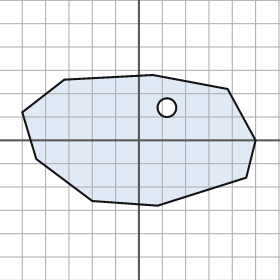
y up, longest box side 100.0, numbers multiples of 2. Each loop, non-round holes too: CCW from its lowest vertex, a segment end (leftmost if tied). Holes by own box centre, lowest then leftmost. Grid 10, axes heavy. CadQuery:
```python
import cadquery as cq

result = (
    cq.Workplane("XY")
    .moveTo(8.0, -28.0)
    .lineTo(46.0, -16.0)
    .lineTo(50.0, 0.0)
    .lineTo(38.0, 22.0)
    .lineTo(6.0, 28.0)
    .lineTo(-32.0, 26.0)
    .lineTo(-50.0, 12.0)
    .lineTo(-44.0, -8.0)
    .lineTo(-20.0, -26.0)
    .close()
    .moveTo(12.0, 14.0)
    .circle(4.0)
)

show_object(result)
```